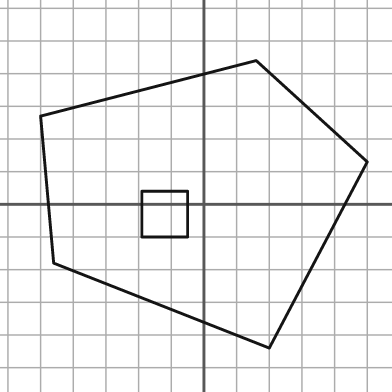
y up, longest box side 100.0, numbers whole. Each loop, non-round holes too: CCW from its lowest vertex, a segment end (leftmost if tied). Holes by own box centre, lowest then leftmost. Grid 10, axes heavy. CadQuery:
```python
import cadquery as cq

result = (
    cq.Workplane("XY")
    .moveTo(20.0, -44.0)
    .lineTo(50.0, 13.0)
    .lineTo(16.0, 44.0)
    .lineTo(-50.0, 27.0)
    .lineTo(-46.0, -18.0)
    .close()
    .moveTo(-19.0, -10.0)
    .lineTo(-5.0, -10.0)
    .lineTo(-5.0, 4.0)
    .lineTo(-19.0, 4.0)
    .close()
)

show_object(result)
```